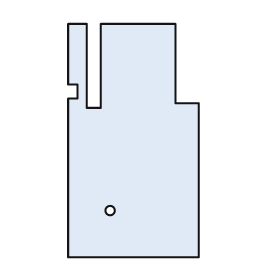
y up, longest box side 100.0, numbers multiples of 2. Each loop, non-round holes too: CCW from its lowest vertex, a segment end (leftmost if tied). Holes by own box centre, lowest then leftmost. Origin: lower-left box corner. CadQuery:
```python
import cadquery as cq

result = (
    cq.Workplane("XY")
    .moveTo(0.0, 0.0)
    .lineTo(56.0, 0.0)
    .lineTo(56.0, 66.0)
    .lineTo(46.0, 66.0)
    .lineTo(46.0, 100.0)
    .lineTo(14.0, 100.0)
    .lineTo(14.0, 64.0)
    .lineTo(8.0, 64.0)
    .lineTo(8.0, 100.0)
    .lineTo(0.0, 100.0)
    .lineTo(0.0, 74.0)
    .lineTo(4.0, 74.0)
    .lineTo(4.0, 68.0)
    .lineTo(0.0, 68.0)
    .close()
    .moveTo(18.0, 20.0)
    .circle(2.0)
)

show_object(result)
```